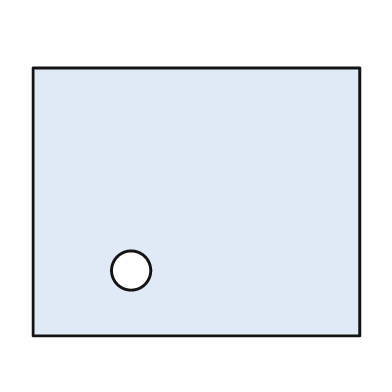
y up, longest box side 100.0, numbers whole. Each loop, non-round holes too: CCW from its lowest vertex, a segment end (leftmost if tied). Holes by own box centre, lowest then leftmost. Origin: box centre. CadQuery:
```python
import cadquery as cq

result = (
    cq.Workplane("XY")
    .moveTo(-50.0, -41.0)
    .lineTo(50.0, -41.0)
    .lineTo(50.0, 41.0)
    .lineTo(-50.0, 41.0)
    .close()
    .moveTo(-20.0, -21.0)
    .circle(6.0)
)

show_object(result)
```